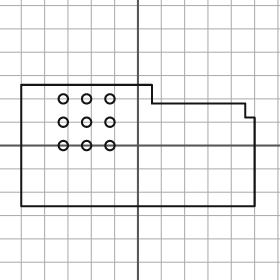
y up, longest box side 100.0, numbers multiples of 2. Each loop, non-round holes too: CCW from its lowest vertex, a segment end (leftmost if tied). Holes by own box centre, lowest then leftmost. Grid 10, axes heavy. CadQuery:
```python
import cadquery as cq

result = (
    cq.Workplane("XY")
    .moveTo(-50.0, -26.0)
    .lineTo(50.0, -26.0)
    .lineTo(50.0, 12.0)
    .lineTo(46.0, 12.0)
    .lineTo(46.0, 18.0)
    .lineTo(6.0, 18.0)
    .lineTo(6.0, 26.0)
    .lineTo(-50.0, 26.0)
    .close()
    .moveTo(-32.0, 0.0)
    .circle(2.0)
    .moveTo(-22.0, 0.0)
    .circle(2.0)
    .moveTo(-12.0, 0.0)
    .circle(2.0)
    .moveTo(-32.0, 10.0)
    .circle(2.0)
    .moveTo(-22.0, 10.0)
    .circle(2.0)
    .moveTo(-12.0, 10.0)
    .circle(2.0)
    .moveTo(-32.0, 20.0)
    .circle(2.0)
    .moveTo(-22.0, 20.0)
    .circle(2.0)
    .moveTo(-12.0, 20.0)
    .circle(2.0)
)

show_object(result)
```